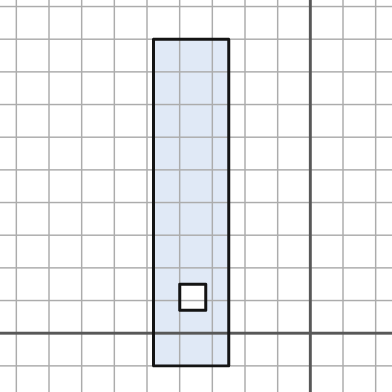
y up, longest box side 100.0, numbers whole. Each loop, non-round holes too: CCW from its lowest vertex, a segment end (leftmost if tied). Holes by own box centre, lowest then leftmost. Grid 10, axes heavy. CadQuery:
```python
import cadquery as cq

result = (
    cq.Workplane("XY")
    .moveTo(-48.0, -10.0)
    .lineTo(-25.0, -10.0)
    .lineTo(-25.0, 90.0)
    .lineTo(-48.0, 90.0)
    .close()
    .moveTo(-40.0, 7.0)
    .lineTo(-32.0, 7.0)
    .lineTo(-32.0, 15.0)
    .lineTo(-40.0, 15.0)
    .close()
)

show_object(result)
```